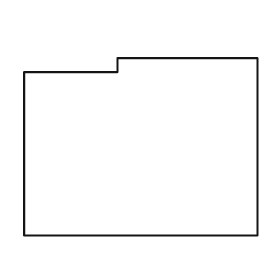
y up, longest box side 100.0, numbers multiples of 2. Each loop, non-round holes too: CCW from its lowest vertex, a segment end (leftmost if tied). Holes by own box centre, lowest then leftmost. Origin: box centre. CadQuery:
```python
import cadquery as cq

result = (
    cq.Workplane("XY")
    .moveTo(-50.0, -38.0)
    .lineTo(50.0, -38.0)
    .lineTo(50.0, 38.0)
    .lineTo(-10.0, 38.0)
    .lineTo(-10.0, 32.0)
    .lineTo(-50.0, 32.0)
    .close()
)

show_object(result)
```